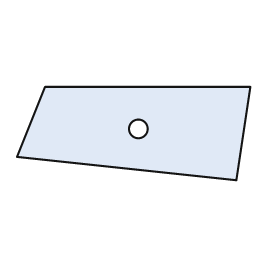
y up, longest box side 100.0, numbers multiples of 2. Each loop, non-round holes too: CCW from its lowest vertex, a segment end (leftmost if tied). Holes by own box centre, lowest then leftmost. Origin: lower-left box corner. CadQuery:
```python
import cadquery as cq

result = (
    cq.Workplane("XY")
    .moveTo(94.0, 0.0)
    .lineTo(100.0, 40.0)
    .lineTo(12.0, 40.0)
    .lineTo(0.0, 10.0)
    .close()
    .moveTo(52.0, 22.0)
    .circle(4.0)
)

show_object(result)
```